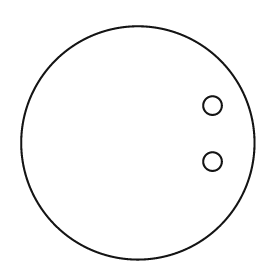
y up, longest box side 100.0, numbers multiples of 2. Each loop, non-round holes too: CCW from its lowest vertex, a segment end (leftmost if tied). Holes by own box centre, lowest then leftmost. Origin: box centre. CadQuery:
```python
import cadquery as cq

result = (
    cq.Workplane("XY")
    .moveTo(0.0, 0.0)
    .circle(50.0)
    .moveTo(32.0, -8.0)
    .circle(4.0)
    .moveTo(32.0, 16.0)
    .circle(4.0)
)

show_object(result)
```